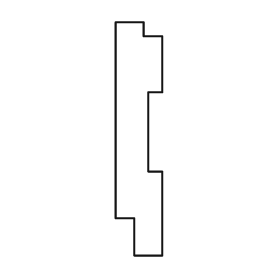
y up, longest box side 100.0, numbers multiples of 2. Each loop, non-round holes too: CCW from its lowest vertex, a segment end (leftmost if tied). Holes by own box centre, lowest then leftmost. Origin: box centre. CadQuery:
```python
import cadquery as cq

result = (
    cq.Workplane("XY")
    .moveTo(-2.0, -50.0)
    .lineTo(10.0, -50.0)
    .lineTo(10.0, -14.0)
    .lineTo(4.0, -14.0)
    .lineTo(4.0, 20.0)
    .lineTo(10.0, 20.0)
    .lineTo(10.0, 44.0)
    .lineTo(2.0, 44.0)
    .lineTo(2.0, 50.0)
    .lineTo(-10.0, 50.0)
    .lineTo(-10.0, -34.0)
    .lineTo(-2.0, -34.0)
    .close()
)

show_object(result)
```